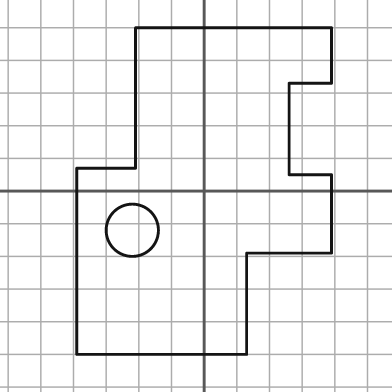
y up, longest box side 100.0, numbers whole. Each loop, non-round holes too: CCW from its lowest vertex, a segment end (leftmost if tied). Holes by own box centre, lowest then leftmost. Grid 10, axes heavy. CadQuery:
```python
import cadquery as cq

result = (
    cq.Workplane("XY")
    .moveTo(-39.0, -50.0)
    .lineTo(13.0, -50.0)
    .lineTo(13.0, -19.0)
    .lineTo(39.0, -19.0)
    .lineTo(39.0, 5.0)
    .lineTo(26.0, 5.0)
    .lineTo(26.0, 33.0)
    .lineTo(39.0, 33.0)
    .lineTo(39.0, 50.0)
    .lineTo(-21.0, 50.0)
    .lineTo(-21.0, 7.0)
    .lineTo(-39.0, 7.0)
    .close()
    .moveTo(-22.0, -12.0)
    .circle(8.0)
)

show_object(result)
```